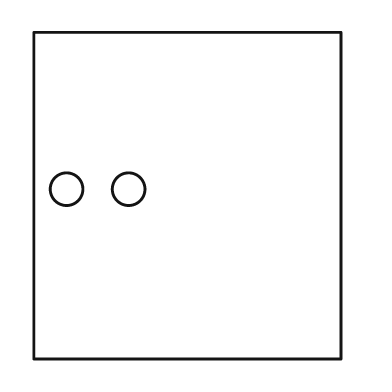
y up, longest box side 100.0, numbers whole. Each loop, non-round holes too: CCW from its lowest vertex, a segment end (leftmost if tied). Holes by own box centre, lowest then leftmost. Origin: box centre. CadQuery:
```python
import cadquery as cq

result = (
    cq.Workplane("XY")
    .moveTo(-47.0, -50.0)
    .lineTo(47.0, -50.0)
    .lineTo(47.0, 50.0)
    .lineTo(-47.0, 50.0)
    .close()
    .moveTo(-37.0, 2.0)
    .circle(5.0)
    .moveTo(-18.0, 2.0)
    .circle(5.0)
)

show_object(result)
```